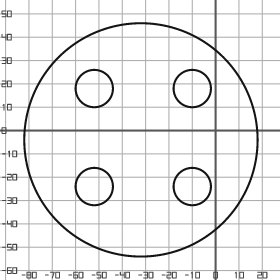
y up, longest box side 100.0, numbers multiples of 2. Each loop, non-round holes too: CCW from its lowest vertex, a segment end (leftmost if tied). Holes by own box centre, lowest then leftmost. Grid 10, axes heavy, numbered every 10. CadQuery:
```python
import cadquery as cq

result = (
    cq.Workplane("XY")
    .moveTo(-32.0, -4.0)
    .circle(50.0)
    .moveTo(-52.0, -24.0)
    .circle(8.0)
    .moveTo(-10.0, -24.0)
    .circle(8.0)
    .moveTo(-52.0, 18.0)
    .circle(8.0)
    .moveTo(-10.0, 18.0)
    .circle(8.0)
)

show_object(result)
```